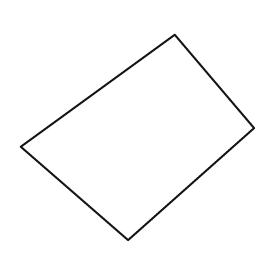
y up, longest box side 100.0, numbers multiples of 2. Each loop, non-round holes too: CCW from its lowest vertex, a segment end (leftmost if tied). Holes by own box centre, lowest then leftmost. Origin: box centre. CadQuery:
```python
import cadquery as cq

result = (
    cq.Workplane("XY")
    .moveTo(-4.0, -44.0)
    .lineTo(50.0, 4.0)
    .lineTo(16.0, 44.0)
    .lineTo(-50.0, -4.0)
    .close()
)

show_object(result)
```